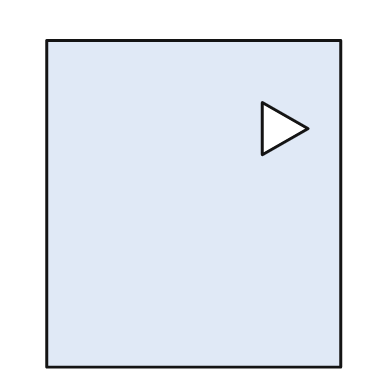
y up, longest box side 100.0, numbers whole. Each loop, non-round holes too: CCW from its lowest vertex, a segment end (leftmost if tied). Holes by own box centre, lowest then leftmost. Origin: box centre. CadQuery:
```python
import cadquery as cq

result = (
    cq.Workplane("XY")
    .moveTo(-45.0, -50.0)
    .lineTo(45.0, -50.0)
    .lineTo(45.0, 50.0)
    .lineTo(-45.0, 50.0)
    .close()
    .moveTo(21.0, 15.0)
    .lineTo(35.0, 23.0)
    .lineTo(21.0, 31.0)
    .close()
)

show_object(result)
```